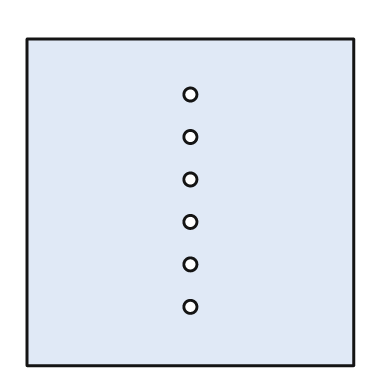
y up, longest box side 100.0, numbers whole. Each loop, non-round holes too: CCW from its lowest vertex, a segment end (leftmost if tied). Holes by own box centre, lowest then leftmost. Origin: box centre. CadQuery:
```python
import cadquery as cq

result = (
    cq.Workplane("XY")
    .moveTo(-50.0, -50.0)
    .lineTo(50.0, -50.0)
    .lineTo(50.0, 50.0)
    .lineTo(-50.0, 50.0)
    .close()
    .moveTo(0.0, -32.0)
    .circle(2.0)
    .moveTo(0.0, -19.0)
    .circle(2.0)
    .moveTo(0.0, -6.0)
    .circle(2.0)
    .moveTo(0.0, 7.0)
    .circle(2.0)
    .moveTo(0.0, 20.0)
    .circle(2.0)
    .moveTo(0.0, 33.0)
    .circle(2.0)
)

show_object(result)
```